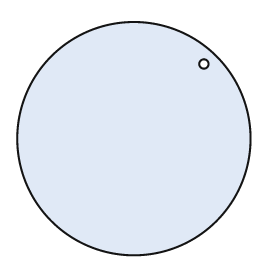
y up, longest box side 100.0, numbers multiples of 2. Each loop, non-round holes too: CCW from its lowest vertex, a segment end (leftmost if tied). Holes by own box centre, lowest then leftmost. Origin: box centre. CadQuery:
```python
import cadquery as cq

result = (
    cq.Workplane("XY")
    .moveTo(0.0, 0.0)
    .circle(50.0)
    .moveTo(30.0, 32.0)
    .circle(2.0)
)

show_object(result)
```